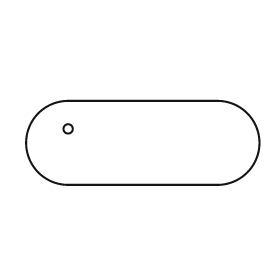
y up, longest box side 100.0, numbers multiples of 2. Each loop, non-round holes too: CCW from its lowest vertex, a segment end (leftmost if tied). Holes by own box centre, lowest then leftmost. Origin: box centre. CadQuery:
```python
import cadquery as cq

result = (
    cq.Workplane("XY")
    .moveTo(-32.0, -18.0)
    .lineTo(32.0, -18.0)
    .threePointArc((50.0, 0.0), (32.0, 18.0))
    .lineTo(-32.0, 18.0)
    .threePointArc((-50.0, 0.0), (-32.0, -18.0))
    .close()
    .moveTo(-32.0, 6.0)
    .circle(2.0)
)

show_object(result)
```